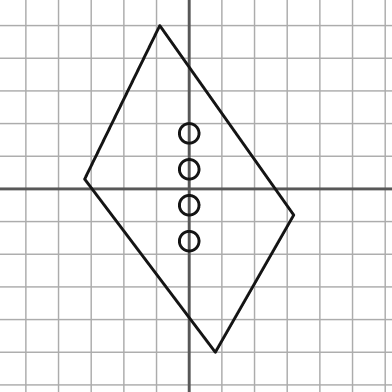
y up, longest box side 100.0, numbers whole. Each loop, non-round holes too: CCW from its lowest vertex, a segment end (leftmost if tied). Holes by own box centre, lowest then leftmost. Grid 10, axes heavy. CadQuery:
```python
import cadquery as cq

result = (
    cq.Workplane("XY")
    .moveTo(8.0, -50.0)
    .lineTo(32.0, -8.0)
    .lineTo(-9.0, 50.0)
    .lineTo(-32.0, 3.0)
    .close()
    .moveTo(0.0, -16.0)
    .circle(3.0)
    .moveTo(0.0, -5.0)
    .circle(3.0)
    .moveTo(0.0, 6.0)
    .circle(3.0)
    .moveTo(0.0, 17.0)
    .circle(3.0)
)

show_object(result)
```